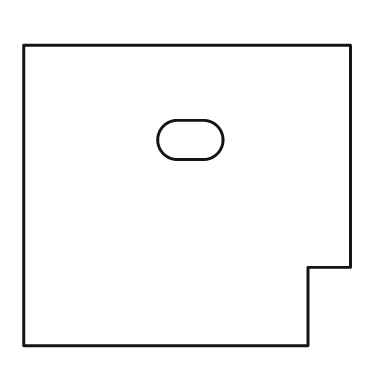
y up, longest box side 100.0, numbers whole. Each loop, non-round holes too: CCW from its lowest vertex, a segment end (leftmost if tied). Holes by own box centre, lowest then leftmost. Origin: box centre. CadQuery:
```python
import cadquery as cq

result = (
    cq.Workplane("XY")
    .moveTo(-50.0, -46.0)
    .lineTo(37.0, -46.0)
    .lineTo(37.0, -22.0)
    .lineTo(50.0, -22.0)
    .lineTo(50.0, 46.0)
    .lineTo(-50.0, 46.0)
    .close()
    .moveTo(-3.0, 11.0)
    .lineTo(5.0, 11.0)
    .threePointArc((11.0, 17.0), (5.0, 23.0))
    .lineTo(-3.0, 23.0)
    .threePointArc((-9.0, 17.0), (-3.0, 11.0))
    .close()
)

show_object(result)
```